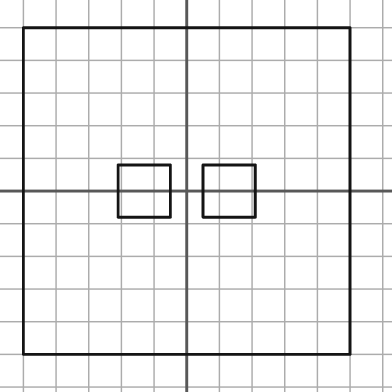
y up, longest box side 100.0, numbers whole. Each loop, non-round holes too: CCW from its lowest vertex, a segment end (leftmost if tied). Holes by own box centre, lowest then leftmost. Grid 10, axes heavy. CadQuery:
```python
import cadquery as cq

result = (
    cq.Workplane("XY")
    .moveTo(-50.0, -50.0)
    .lineTo(50.0, -50.0)
    .lineTo(50.0, 50.0)
    .lineTo(-50.0, 50.0)
    .close()
    .moveTo(-21.0, -8.0)
    .lineTo(-5.0, -8.0)
    .lineTo(-5.0, 8.0)
    .lineTo(-21.0, 8.0)
    .close()
    .moveTo(5.0, -8.0)
    .lineTo(21.0, -8.0)
    .lineTo(21.0, 8.0)
    .lineTo(5.0, 8.0)
    .close()
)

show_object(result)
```